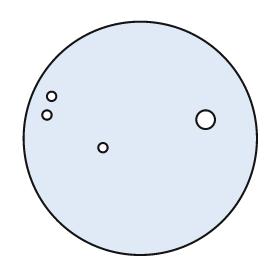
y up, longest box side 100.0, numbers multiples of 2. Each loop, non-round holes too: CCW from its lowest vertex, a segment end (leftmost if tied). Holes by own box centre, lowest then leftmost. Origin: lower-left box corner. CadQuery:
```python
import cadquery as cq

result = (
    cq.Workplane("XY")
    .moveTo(50.0, 50.0)
    .circle(50.0)
    .moveTo(34.0, 46.0)
    .circle(2.0)
    .moveTo(78.0, 58.0)
    .circle(4.0)
    .moveTo(10.0, 60.0)
    .circle(2.0)
    .moveTo(12.0, 68.0)
    .circle(2.0)
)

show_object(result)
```